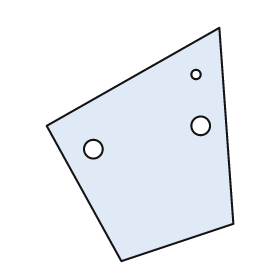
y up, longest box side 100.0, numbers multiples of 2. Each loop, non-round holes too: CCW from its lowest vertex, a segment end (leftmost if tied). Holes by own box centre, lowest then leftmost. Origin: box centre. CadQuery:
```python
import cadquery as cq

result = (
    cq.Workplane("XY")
    .moveTo(-8.0, -50.0)
    .lineTo(40.0, -34.0)
    .lineTo(34.0, 50.0)
    .lineTo(-40.0, 8.0)
    .close()
    .moveTo(-20.0, -2.0)
    .circle(4.0)
    .moveTo(26.0, 8.0)
    .circle(4.0)
    .moveTo(24.0, 30.0)
    .circle(2.0)
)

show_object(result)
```